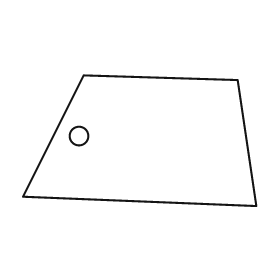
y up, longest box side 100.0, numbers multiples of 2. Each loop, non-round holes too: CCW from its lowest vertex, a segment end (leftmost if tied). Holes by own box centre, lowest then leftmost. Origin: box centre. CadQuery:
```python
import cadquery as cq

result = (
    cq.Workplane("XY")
    .moveTo(50.0, -28.0)
    .lineTo(42.0, 26.0)
    .lineTo(-24.0, 28.0)
    .lineTo(-50.0, -24.0)
    .close()
    .moveTo(-26.0, 2.0)
    .circle(4.0)
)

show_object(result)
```